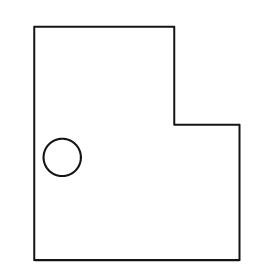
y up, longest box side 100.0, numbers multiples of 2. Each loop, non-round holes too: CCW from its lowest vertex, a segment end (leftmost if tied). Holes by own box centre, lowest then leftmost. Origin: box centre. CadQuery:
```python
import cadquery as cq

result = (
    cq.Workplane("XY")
    .moveTo(-44.0, -50.0)
    .lineTo(44.0, -50.0)
    .lineTo(44.0, 8.0)
    .lineTo(16.0, 8.0)
    .lineTo(16.0, 50.0)
    .lineTo(-44.0, 50.0)
    .close()
    .moveTo(-32.0, -6.0)
    .circle(8.0)
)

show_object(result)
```